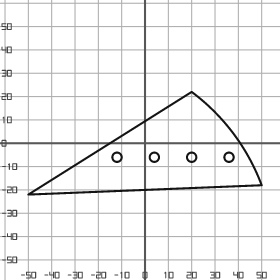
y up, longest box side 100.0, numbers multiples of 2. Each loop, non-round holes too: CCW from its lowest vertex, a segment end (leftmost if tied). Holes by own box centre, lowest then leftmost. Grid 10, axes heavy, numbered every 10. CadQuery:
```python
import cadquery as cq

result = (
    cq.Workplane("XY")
    .moveTo(-50.0, -22.0)
    .lineTo(50.0, -18.0)
    .threePointArc((38.0, 4.0), (20.0, 22.0))
    .close()
    .moveTo(-12.0, -6.0)
    .circle(2.0)
    .moveTo(4.0, -6.0)
    .circle(2.0)
    .moveTo(20.0, -6.0)
    .circle(2.0)
    .moveTo(36.0, -6.0)
    .circle(2.0)
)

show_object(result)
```